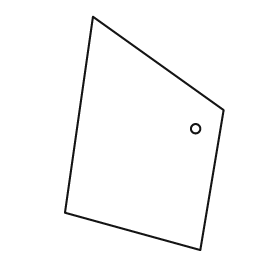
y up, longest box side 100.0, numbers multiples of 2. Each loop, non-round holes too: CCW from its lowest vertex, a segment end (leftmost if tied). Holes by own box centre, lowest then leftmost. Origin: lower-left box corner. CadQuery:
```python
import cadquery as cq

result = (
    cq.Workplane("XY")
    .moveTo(58.0, 0.0)
    .lineTo(68.0, 60.0)
    .lineTo(12.0, 100.0)
    .lineTo(0.0, 16.0)
    .close()
    .moveTo(56.0, 52.0)
    .circle(2.0)
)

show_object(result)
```